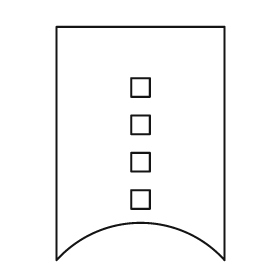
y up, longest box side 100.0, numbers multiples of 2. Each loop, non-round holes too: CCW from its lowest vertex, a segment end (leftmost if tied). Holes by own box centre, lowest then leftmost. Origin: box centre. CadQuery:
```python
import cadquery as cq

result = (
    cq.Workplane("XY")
    .moveTo(-36.0, -50.0)
    .threePointArc((0.0, -34.0), (36.0, -50.0))
    .lineTo(36.0, 50.0)
    .lineTo(-36.0, 50.0)
    .close()
    .moveTo(-4.0, -28.0)
    .lineTo(4.0, -28.0)
    .lineTo(4.0, -20.0)
    .lineTo(-4.0, -20.0)
    .close()
    .moveTo(-4.0, -12.0)
    .lineTo(4.0, -12.0)
    .lineTo(4.0, -4.0)
    .lineTo(-4.0, -4.0)
    .close()
    .moveTo(-4.0, 4.0)
    .lineTo(4.0, 4.0)
    .lineTo(4.0, 12.0)
    .lineTo(-4.0, 12.0)
    .close()
    .moveTo(-4.0, 20.0)
    .lineTo(4.0, 20.0)
    .lineTo(4.0, 28.0)
    .lineTo(-4.0, 28.0)
    .close()
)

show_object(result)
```